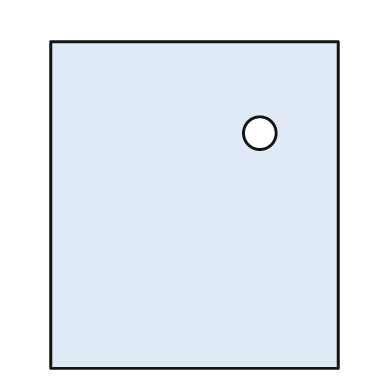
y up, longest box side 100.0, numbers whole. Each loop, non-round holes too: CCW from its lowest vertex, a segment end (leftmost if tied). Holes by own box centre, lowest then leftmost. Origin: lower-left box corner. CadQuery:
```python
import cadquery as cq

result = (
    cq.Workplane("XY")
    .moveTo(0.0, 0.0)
    .lineTo(88.0, 0.0)
    .lineTo(88.0, 100.0)
    .lineTo(0.0, 100.0)
    .close()
    .moveTo(64.0, 72.0)
    .circle(5.0)
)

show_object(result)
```